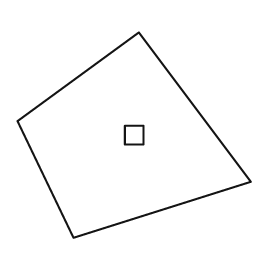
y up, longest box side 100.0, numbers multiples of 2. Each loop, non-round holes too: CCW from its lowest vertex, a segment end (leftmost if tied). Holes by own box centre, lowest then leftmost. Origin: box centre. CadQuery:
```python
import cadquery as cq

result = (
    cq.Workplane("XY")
    .moveTo(-26.0, -44.0)
    .lineTo(50.0, -20.0)
    .lineTo(2.0, 44.0)
    .lineTo(-50.0, 6.0)
    .close()
    .moveTo(-4.0, -4.0)
    .lineTo(4.0, -4.0)
    .lineTo(4.0, 4.0)
    .lineTo(-4.0, 4.0)
    .close()
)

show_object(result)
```